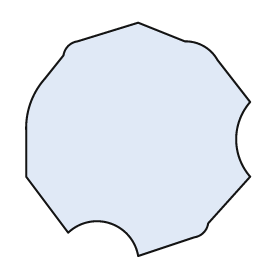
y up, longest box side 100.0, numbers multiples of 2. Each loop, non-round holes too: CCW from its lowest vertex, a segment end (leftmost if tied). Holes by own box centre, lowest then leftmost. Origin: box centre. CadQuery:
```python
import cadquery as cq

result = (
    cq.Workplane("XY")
    .moveTo(0.0, -50.0)
    .lineTo(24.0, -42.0)
    .threePointArc((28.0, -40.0), (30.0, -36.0))
    .lineTo(48.0, -16.0)
    .threePointArc((42.0, 0.0), (48.0, 16.0))
    .lineTo(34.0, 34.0)
    .threePointArc((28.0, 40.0), (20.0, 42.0))
    .lineTo(0.0, 50.0)
    .lineTo(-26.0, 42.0)
    .threePointArc((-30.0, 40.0), (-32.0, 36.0))
    .lineTo(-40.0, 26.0)
    .threePointArc((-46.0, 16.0), (-48.0, 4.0))
    .lineTo(-48.0, -16.0)
    .lineTo(-30.0, -40.0)
    .threePointArc((-12.0, -36.0), (0.0, -50.0))
    .close()
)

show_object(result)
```